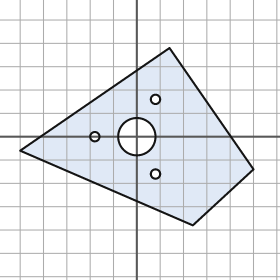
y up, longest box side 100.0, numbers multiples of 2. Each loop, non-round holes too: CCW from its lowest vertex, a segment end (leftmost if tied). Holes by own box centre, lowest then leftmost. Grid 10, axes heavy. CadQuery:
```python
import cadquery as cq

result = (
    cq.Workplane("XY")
    .moveTo(24.0, -38.0)
    .lineTo(50.0, -14.0)
    .lineTo(14.0, 38.0)
    .lineTo(-50.0, -6.0)
    .close()
    .moveTo(8.0, -16.0)
    .circle(2.0)
    .moveTo(-18.0, 0.0)
    .circle(2.0)
    .moveTo(0.0, 0.0)
    .circle(8.0)
    .moveTo(8.0, 16.0)
    .circle(2.0)
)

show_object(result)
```